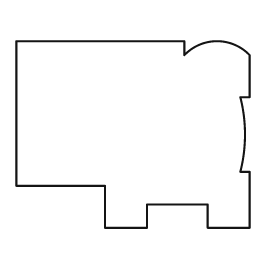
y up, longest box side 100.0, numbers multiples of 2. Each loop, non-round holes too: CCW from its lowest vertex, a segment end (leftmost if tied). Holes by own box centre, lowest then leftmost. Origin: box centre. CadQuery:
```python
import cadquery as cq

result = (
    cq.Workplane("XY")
    .moveTo(-12.0, -40.0)
    .lineTo(6.0, -40.0)
    .lineTo(6.0, -30.0)
    .lineTo(32.0, -30.0)
    .lineTo(32.0, -40.0)
    .lineTo(50.0, -40.0)
    .lineTo(50.0, -16.0)
    .lineTo(46.0, -16.0)
    .threePointArc((48.0, 0.0), (46.0, 16.0))
    .lineTo(50.0, 16.0)
    .lineTo(50.0, 34.0)
    .threePointArc((36.0, 40.0), (22.0, 34.0))
    .lineTo(22.0, 40.0)
    .lineTo(-50.0, 40.0)
    .lineTo(-50.0, -22.0)
    .lineTo(-12.0, -22.0)
    .close()
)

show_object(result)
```